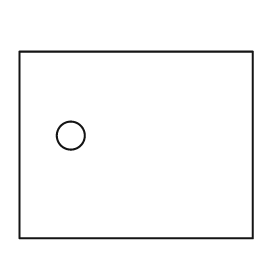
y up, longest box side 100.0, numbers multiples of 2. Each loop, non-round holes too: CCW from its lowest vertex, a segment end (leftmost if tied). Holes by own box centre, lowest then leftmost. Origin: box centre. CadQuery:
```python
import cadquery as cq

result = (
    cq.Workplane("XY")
    .moveTo(-50.0, -40.0)
    .lineTo(50.0, -40.0)
    .lineTo(50.0, 40.0)
    .lineTo(-50.0, 40.0)
    .close()
    .moveTo(-28.0, 4.0)
    .circle(6.0)
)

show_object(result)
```